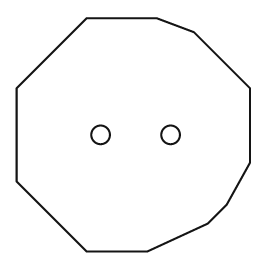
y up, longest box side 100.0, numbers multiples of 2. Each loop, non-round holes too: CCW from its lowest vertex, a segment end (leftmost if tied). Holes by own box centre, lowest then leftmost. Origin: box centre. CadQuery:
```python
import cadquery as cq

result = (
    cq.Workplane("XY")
    .moveTo(-20.0, -50.0)
    .lineTo(6.0, -50.0)
    .lineTo(32.0, -38.0)
    .lineTo(40.0, -30.0)
    .lineTo(50.0, -12.0)
    .lineTo(50.0, 20.0)
    .lineTo(26.0, 44.0)
    .lineTo(10.0, 50.0)
    .lineTo(-20.0, 50.0)
    .lineTo(-50.0, 20.0)
    .lineTo(-50.0, -20.0)
    .close()
    .moveTo(-14.0, 0.0)
    .circle(4.0)
    .moveTo(16.0, 0.0)
    .circle(4.0)
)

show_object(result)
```